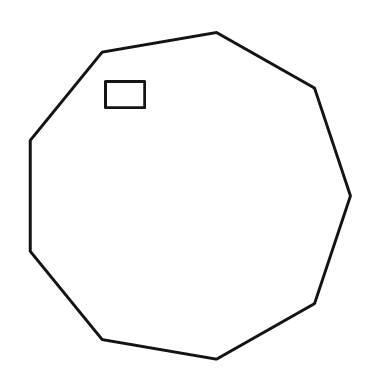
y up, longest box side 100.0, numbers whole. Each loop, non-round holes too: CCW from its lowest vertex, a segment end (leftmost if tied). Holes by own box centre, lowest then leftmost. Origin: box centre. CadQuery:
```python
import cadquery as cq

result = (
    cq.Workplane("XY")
    .moveTo(8.0, -50.0)
    .lineTo(38.0, -33.0)
    .lineTo(49.0, 0.0)
    .lineTo(38.0, 33.0)
    .lineTo(8.0, 50.0)
    .lineTo(-27.0, 44.0)
    .lineTo(-49.0, 17.0)
    .lineTo(-49.0, -17.0)
    .lineTo(-27.0, -44.0)
    .close()
    .moveTo(-26.0, 27.0)
    .lineTo(-14.0, 27.0)
    .lineTo(-14.0, 35.0)
    .lineTo(-26.0, 35.0)
    .close()
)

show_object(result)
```